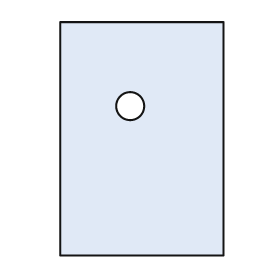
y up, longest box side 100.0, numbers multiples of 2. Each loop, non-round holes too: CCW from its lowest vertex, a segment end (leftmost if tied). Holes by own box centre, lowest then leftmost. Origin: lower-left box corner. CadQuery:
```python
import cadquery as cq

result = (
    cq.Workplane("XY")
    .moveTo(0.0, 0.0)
    .lineTo(70.0, 0.0)
    .lineTo(70.0, 100.0)
    .lineTo(0.0, 100.0)
    .close()
    .moveTo(30.0, 64.0)
    .circle(6.0)
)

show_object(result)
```